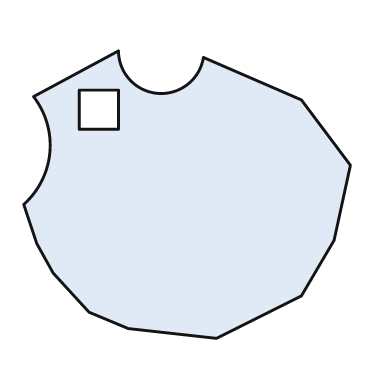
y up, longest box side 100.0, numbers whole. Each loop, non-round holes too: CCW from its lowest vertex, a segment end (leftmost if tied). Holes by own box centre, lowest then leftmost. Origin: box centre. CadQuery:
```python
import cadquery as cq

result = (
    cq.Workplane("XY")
    .moveTo(9.0, -44.0)
    .lineTo(35.0, -31.0)
    .lineTo(45.0, -14.0)
    .lineTo(50.0, 9.0)
    .lineTo(35.0, 29.0)
    .lineTo(5.0, 42.0)
    .threePointArc((-9.0, 31.0), (-21.0, 44.0))
    .lineTo(-47.0, 30.0)
    .threePointArc((-42.0, 13.0), (-50.0, -3.0))
    .lineTo(-46.0, -15.0)
    .lineTo(-41.0, -24.0)
    .lineTo(-30.0, -36.0)
    .lineTo(-18.0, -41.0)
    .close()
    .moveTo(-33.0, 20.0)
    .lineTo(-21.0, 20.0)
    .lineTo(-21.0, 32.0)
    .lineTo(-33.0, 32.0)
    .close()
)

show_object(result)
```